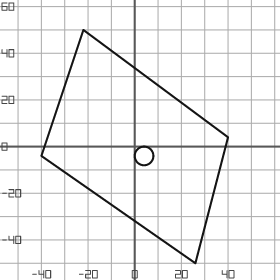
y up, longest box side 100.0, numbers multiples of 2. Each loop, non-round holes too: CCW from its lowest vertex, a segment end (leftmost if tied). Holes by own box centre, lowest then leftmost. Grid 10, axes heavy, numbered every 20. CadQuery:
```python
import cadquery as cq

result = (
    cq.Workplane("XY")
    .moveTo(26.0, -50.0)
    .lineTo(40.0, 4.0)
    .lineTo(-22.0, 50.0)
    .lineTo(-40.0, -4.0)
    .close()
    .moveTo(4.0, -4.0)
    .circle(4.0)
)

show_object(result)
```